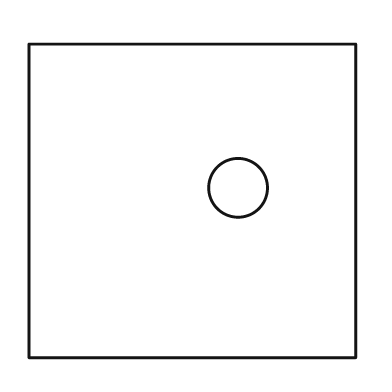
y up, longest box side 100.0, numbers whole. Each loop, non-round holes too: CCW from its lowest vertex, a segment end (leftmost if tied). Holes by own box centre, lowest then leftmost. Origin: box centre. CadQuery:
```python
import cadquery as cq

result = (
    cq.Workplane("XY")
    .moveTo(-50.0, -48.0)
    .lineTo(50.0, -48.0)
    .lineTo(50.0, 48.0)
    .lineTo(-50.0, 48.0)
    .close()
    .moveTo(14.0, 4.0)
    .circle(9.0)
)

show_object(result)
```